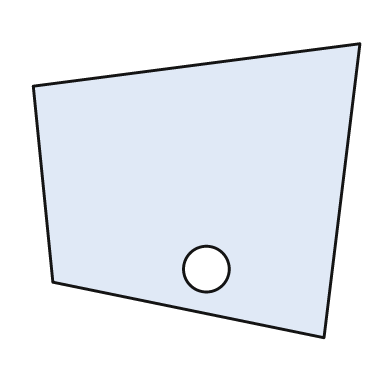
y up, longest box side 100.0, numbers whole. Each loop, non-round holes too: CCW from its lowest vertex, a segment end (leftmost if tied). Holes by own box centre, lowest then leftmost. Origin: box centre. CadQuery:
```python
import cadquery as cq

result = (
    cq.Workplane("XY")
    .moveTo(39.0, -45.0)
    .lineTo(50.0, 45.0)
    .lineTo(-50.0, 32.0)
    .lineTo(-44.0, -28.0)
    .close()
    .moveTo(3.0, -24.0)
    .circle(7.0)
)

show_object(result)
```